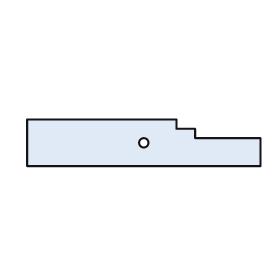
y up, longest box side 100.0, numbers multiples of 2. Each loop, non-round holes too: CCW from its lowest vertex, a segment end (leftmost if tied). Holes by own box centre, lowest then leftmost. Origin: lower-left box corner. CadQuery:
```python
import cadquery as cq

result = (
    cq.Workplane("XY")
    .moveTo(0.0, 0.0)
    .lineTo(100.0, 0.0)
    .lineTo(100.0, 12.0)
    .lineTo(72.0, 12.0)
    .lineTo(72.0, 16.0)
    .lineTo(64.0, 16.0)
    .lineTo(64.0, 20.0)
    .lineTo(0.0, 20.0)
    .close()
    .moveTo(50.0, 10.0)
    .circle(2.0)
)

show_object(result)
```